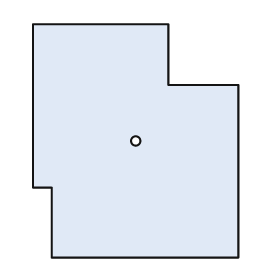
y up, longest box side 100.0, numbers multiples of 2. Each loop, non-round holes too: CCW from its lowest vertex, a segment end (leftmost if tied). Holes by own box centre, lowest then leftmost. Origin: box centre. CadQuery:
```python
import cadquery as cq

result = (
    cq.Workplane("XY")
    .moveTo(-36.0, -50.0)
    .lineTo(44.0, -50.0)
    .lineTo(44.0, 24.0)
    .lineTo(14.0, 24.0)
    .lineTo(14.0, 50.0)
    .lineTo(-44.0, 50.0)
    .lineTo(-44.0, -20.0)
    .lineTo(-36.0, -20.0)
    .close()
    .moveTo(0.0, 0.0)
    .circle(2.0)
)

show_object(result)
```